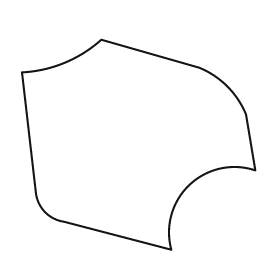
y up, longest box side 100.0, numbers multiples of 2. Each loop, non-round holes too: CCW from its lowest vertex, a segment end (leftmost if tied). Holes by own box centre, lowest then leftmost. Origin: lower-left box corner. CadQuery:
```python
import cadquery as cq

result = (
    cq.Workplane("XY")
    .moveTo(64.0, 0.0)
    .threePointArc((72.0, 28.0), (100.0, 34.0))
    .lineTo(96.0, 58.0)
    .threePointArc((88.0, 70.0), (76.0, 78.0))
    .lineTo(34.0, 90.0)
    .threePointArc((18.0, 80.0), (0.0, 76.0))
    .lineTo(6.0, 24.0)
    .threePointArc((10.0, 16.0), (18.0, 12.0))
    .close()
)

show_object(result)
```